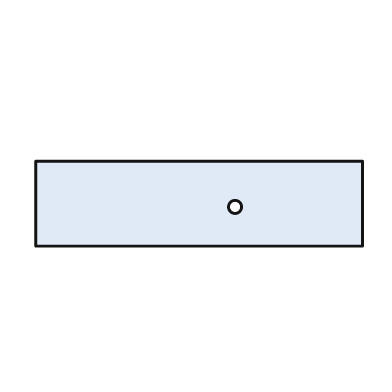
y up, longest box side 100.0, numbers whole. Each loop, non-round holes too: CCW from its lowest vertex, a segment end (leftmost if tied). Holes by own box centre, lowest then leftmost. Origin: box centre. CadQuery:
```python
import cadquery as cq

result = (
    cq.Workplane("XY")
    .moveTo(-50.0, -13.0)
    .lineTo(50.0, -13.0)
    .lineTo(50.0, 13.0)
    .lineTo(-50.0, 13.0)
    .close()
    .moveTo(11.0, -1.0)
    .circle(2.0)
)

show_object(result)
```